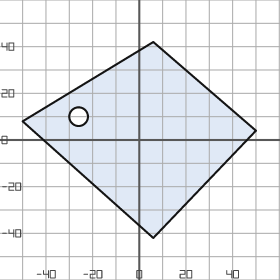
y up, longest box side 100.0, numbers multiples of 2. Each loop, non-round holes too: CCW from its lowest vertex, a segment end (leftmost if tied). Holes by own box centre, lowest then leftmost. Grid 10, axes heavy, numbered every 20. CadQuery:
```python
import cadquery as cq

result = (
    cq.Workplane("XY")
    .moveTo(6.0, -42.0)
    .lineTo(50.0, 4.0)
    .lineTo(6.0, 42.0)
    .lineTo(-50.0, 8.0)
    .close()
    .moveTo(-26.0, 10.0)
    .circle(4.0)
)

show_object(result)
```